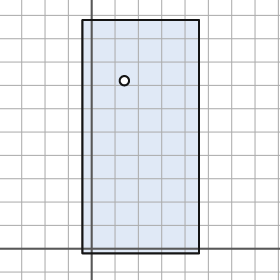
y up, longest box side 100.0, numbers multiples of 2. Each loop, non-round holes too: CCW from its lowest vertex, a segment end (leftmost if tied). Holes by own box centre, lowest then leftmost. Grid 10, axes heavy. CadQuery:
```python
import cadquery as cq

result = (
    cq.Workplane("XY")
    .moveTo(-4.0, -2.0)
    .lineTo(46.0, -2.0)
    .lineTo(46.0, 98.0)
    .lineTo(-4.0, 98.0)
    .close()
    .moveTo(14.0, 72.0)
    .circle(2.0)
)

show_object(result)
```